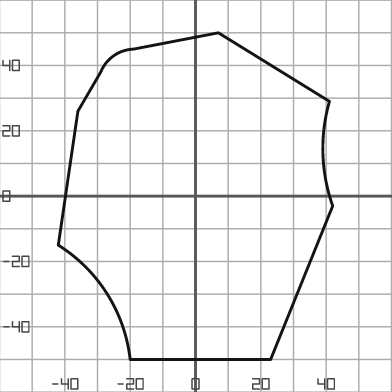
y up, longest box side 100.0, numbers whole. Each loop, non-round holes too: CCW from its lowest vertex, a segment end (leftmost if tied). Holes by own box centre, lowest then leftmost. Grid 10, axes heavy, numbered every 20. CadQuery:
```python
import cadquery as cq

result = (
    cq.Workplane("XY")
    .moveTo(-20.0, -50.0)
    .lineTo(23.0, -50.0)
    .lineTo(42.0, -3.0)
    .threePointArc((39.0, 13.0), (41.0, 29.0))
    .lineTo(7.0, 50.0)
    .lineTo(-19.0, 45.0)
    .threePointArc((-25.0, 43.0), (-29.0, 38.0))
    .lineTo(-36.0, 26.0)
    .lineTo(-42.0, -15.0)
    .threePointArc((-27.0, -30.0), (-20.0, -50.0))
    .close()
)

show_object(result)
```